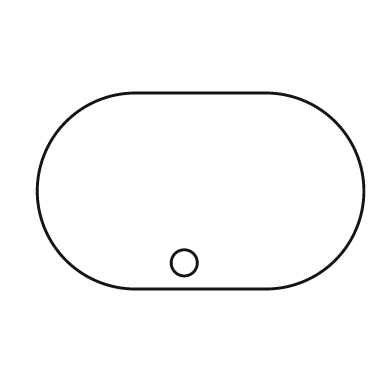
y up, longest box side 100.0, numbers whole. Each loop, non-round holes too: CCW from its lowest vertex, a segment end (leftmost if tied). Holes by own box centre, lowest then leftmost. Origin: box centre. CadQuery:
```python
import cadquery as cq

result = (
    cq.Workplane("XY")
    .moveTo(-20.0, -30.0)
    .lineTo(20.0, -30.0)
    .threePointArc((50.0, 0.0), (20.0, 30.0))
    .lineTo(-20.0, 30.0)
    .threePointArc((-50.0, 0.0), (-20.0, -30.0))
    .close()
    .moveTo(-5.0, -22.0)
    .circle(4.0)
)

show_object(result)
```